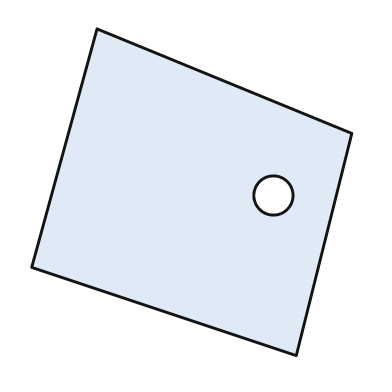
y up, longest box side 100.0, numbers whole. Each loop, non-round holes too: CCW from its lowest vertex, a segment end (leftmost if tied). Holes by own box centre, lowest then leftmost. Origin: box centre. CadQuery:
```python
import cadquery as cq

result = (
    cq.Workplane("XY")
    .moveTo(32.0, -50.0)
    .lineTo(49.0, 18.0)
    .lineTo(-29.0, 50.0)
    .lineTo(-49.0, -23.0)
    .close()
    .moveTo(25.0, -1.0)
    .circle(6.0)
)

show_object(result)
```